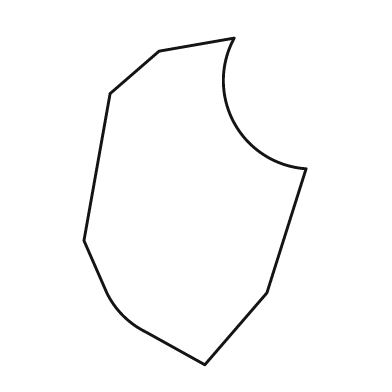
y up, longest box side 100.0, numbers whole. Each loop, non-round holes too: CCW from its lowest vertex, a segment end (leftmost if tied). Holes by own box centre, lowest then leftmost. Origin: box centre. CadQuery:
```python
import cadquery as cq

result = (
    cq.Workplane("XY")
    .moveTo(3.0, -50.0)
    .lineTo(22.0, -28.0)
    .lineTo(34.0, 10.0)
    .threePointArc((12.0, 24.0), (12.0, 50.0))
    .lineTo(-11.0, 46.0)
    .lineTo(-26.0, 33.0)
    .lineTo(-34.0, -12.0)
    .lineTo(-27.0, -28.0)
    .threePointArc((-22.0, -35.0), (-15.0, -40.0))
    .close()
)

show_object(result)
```